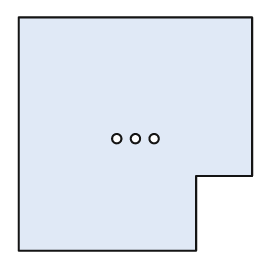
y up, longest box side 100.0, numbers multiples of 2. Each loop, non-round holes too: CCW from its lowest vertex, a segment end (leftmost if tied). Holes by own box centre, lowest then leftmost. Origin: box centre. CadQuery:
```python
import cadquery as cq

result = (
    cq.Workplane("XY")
    .moveTo(-50.0, -50.0)
    .lineTo(26.0, -50.0)
    .lineTo(26.0, -18.0)
    .lineTo(50.0, -18.0)
    .lineTo(50.0, 50.0)
    .lineTo(-50.0, 50.0)
    .close()
    .moveTo(-8.0, -2.0)
    .circle(2.0)
    .moveTo(0.0, -2.0)
    .circle(2.0)
    .moveTo(8.0, -2.0)
    .circle(2.0)
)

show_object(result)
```